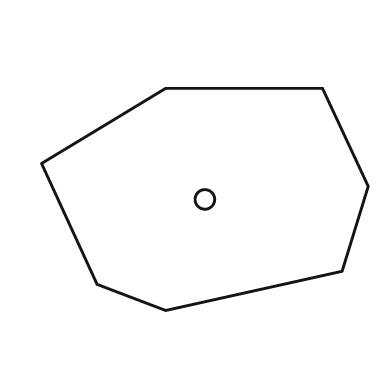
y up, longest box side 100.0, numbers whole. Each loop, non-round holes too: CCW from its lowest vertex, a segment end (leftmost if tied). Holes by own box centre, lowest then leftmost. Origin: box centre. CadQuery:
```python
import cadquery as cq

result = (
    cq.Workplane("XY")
    .moveTo(-12.0, -34.0)
    .lineTo(42.0, -22.0)
    .lineTo(50.0, 4.0)
    .lineTo(36.0, 34.0)
    .lineTo(-12.0, 34.0)
    .lineTo(-50.0, 11.0)
    .lineTo(-33.0, -26.0)
    .close()
    .moveTo(0.0, 0.0)
    .circle(3.0)
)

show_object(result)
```